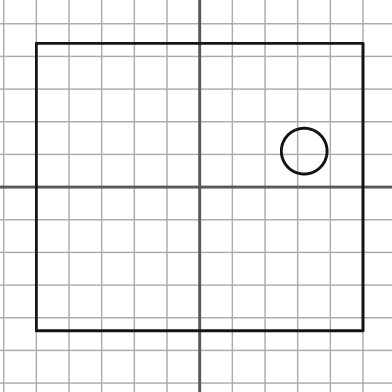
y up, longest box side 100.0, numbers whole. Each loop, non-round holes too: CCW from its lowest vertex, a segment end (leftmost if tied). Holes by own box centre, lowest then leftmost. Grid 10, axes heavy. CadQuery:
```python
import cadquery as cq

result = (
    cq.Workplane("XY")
    .moveTo(-50.0, -44.0)
    .lineTo(50.0, -44.0)
    .lineTo(50.0, 44.0)
    .lineTo(-50.0, 44.0)
    .close()
    .moveTo(32.0, 11.0)
    .circle(7.0)
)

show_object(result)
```